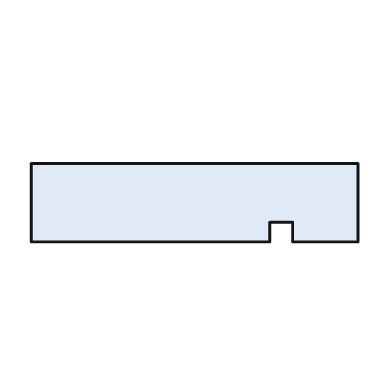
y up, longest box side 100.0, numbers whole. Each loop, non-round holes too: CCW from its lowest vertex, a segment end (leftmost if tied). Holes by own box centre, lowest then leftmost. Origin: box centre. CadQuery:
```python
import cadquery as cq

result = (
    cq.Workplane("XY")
    .moveTo(-50.0, -12.0)
    .lineTo(23.0, -12.0)
    .lineTo(23.0, -6.0)
    .lineTo(30.0, -6.0)
    .lineTo(30.0, -12.0)
    .lineTo(50.0, -12.0)
    .lineTo(50.0, 12.0)
    .lineTo(-50.0, 12.0)
    .close()
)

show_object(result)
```